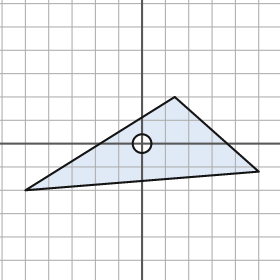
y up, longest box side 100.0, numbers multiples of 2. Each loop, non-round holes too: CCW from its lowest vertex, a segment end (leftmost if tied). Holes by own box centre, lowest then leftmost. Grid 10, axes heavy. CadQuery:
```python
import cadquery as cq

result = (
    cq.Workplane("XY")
    .moveTo(-50.0, -20.0)
    .lineTo(50.0, -12.0)
    .lineTo(14.0, 20.0)
    .close()
    .moveTo(0.0, 0.0)
    .circle(4.0)
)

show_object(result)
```